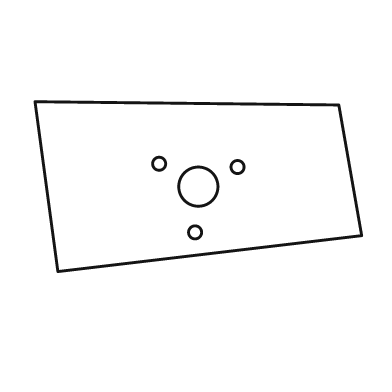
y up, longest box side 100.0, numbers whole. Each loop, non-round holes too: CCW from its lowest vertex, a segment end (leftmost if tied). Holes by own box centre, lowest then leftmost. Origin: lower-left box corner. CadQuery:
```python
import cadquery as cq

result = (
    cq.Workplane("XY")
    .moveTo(7.0, 0.0)
    .lineTo(100.0, 11.0)
    .lineTo(93.0, 51.0)
    .lineTo(0.0, 52.0)
    .close()
    .moveTo(49.0, 12.0)
    .circle(2.0)
    .moveTo(50.0, 26.0)
    .circle(6.0)
    .moveTo(62.0, 32.0)
    .circle(2.0)
    .moveTo(38.0, 33.0)
    .circle(2.0)
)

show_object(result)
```